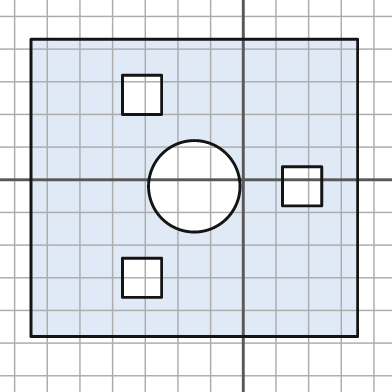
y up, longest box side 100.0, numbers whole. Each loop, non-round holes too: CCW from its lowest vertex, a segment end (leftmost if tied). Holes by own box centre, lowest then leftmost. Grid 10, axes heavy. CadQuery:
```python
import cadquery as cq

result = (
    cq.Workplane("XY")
    .moveTo(-65.0, -48.0)
    .lineTo(35.0, -48.0)
    .lineTo(35.0, 43.0)
    .lineTo(-65.0, 43.0)
    .close()
    .moveTo(-37.0, -36.0)
    .lineTo(-25.0, -36.0)
    .lineTo(-25.0, -24.0)
    .lineTo(-37.0, -24.0)
    .close()
    .moveTo(-15.0, -2.0)
    .circle(14.0)
    .moveTo(12.0, -8.0)
    .lineTo(24.0, -8.0)
    .lineTo(24.0, 4.0)
    .lineTo(12.0, 4.0)
    .close()
    .moveTo(-37.0, 20.0)
    .lineTo(-25.0, 20.0)
    .lineTo(-25.0, 32.0)
    .lineTo(-37.0, 32.0)
    .close()
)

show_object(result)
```